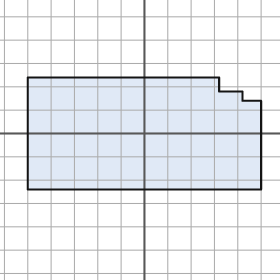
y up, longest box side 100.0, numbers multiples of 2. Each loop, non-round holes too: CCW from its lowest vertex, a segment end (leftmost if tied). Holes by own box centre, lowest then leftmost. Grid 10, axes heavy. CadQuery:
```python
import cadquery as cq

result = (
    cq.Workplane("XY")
    .moveTo(-50.0, -24.0)
    .lineTo(50.0, -24.0)
    .lineTo(50.0, 14.0)
    .lineTo(42.0, 14.0)
    .lineTo(42.0, 18.0)
    .lineTo(32.0, 18.0)
    .lineTo(32.0, 24.0)
    .lineTo(-50.0, 24.0)
    .close()
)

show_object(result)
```